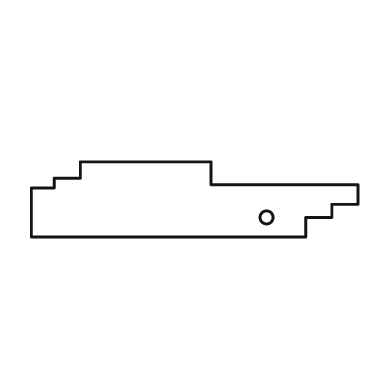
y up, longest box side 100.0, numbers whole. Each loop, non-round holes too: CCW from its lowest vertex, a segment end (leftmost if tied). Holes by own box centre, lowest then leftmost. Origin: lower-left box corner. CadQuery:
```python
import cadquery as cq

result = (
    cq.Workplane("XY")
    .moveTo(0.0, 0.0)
    .lineTo(84.0, 0.0)
    .lineTo(84.0, 6.0)
    .lineTo(92.0, 6.0)
    .lineTo(92.0, 10.0)
    .lineTo(100.0, 10.0)
    .lineTo(100.0, 16.0)
    .lineTo(55.0, 16.0)
    .lineTo(55.0, 23.0)
    .lineTo(15.0, 23.0)
    .lineTo(15.0, 18.0)
    .lineTo(7.0, 18.0)
    .lineTo(7.0, 15.0)
    .lineTo(0.0, 15.0)
    .close()
    .moveTo(72.0, 6.0)
    .circle(2.0)
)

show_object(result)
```